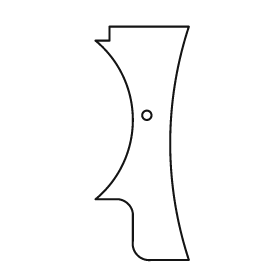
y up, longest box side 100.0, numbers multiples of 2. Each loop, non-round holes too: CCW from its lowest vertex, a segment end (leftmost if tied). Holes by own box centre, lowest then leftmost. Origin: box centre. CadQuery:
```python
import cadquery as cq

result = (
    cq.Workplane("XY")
    .moveTo(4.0, -50.0)
    .lineTo(20.0, -50.0)
    .threePointArc((12.0, 0.0), (20.0, 50.0))
    .lineTo(-14.0, 50.0)
    .lineTo(-14.0, 44.0)
    .lineTo(-20.0, 44.0)
    .threePointArc((-4.0, 10.0), (-20.0, -24.0))
    .lineTo(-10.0, -24.0)
    .threePointArc((-6.0, -26.0), (-4.0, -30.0))
    .lineTo(-4.0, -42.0)
    .threePointArc((-2.0, -48.0), (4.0, -50.0))
    .close()
    .moveTo(2.0, 12.0)
    .circle(2.0)
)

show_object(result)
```